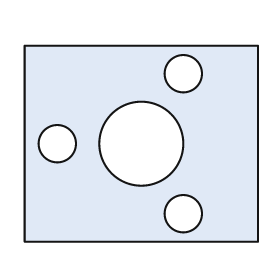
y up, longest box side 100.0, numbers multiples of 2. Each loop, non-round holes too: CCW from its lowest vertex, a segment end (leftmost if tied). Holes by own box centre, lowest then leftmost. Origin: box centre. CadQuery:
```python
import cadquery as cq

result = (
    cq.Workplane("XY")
    .moveTo(-50.0, -42.0)
    .lineTo(50.0, -42.0)
    .lineTo(50.0, 42.0)
    .lineTo(-50.0, 42.0)
    .close()
    .moveTo(18.0, -30.0)
    .circle(8.0)
    .moveTo(-36.0, 0.0)
    .circle(8.0)
    .moveTo(0.0, 0.0)
    .circle(18.0)
    .moveTo(18.0, 30.0)
    .circle(8.0)
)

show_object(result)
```